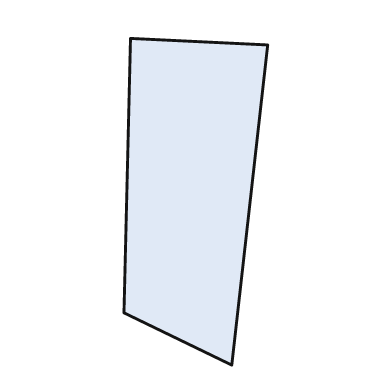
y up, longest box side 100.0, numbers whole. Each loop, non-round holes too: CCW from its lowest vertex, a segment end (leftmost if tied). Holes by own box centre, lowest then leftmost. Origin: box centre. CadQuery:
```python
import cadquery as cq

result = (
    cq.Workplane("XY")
    .moveTo(11.0, -50.0)
    .lineTo(22.0, 48.0)
    .lineTo(-20.0, 50.0)
    .lineTo(-22.0, -34.0)
    .close()
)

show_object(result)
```